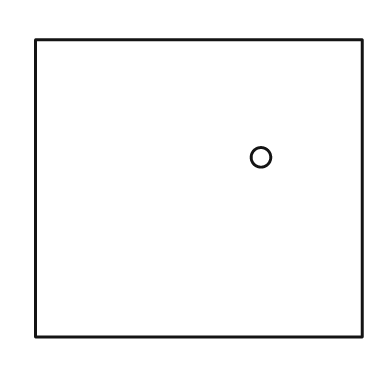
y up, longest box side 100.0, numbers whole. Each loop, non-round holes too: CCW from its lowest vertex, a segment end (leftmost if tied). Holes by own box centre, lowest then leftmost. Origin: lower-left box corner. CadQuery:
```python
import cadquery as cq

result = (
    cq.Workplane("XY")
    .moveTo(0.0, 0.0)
    .lineTo(100.0, 0.0)
    .lineTo(100.0, 91.0)
    .lineTo(0.0, 91.0)
    .close()
    .moveTo(69.0, 55.0)
    .circle(3.0)
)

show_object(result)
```